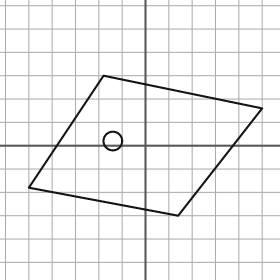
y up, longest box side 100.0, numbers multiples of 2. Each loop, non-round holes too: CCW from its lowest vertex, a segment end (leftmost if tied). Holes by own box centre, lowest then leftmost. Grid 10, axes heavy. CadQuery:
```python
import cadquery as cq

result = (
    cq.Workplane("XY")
    .moveTo(14.0, -30.0)
    .lineTo(50.0, 16.0)
    .lineTo(-18.0, 30.0)
    .lineTo(-50.0, -18.0)
    .close()
    .moveTo(-14.0, 2.0)
    .circle(4.0)
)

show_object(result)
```